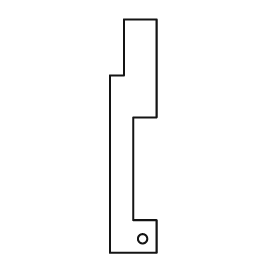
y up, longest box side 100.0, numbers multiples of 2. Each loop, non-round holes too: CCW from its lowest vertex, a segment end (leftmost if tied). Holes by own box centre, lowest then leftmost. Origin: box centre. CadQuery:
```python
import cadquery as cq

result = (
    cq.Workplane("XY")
    .moveTo(-10.0, -50.0)
    .lineTo(10.0, -50.0)
    .lineTo(10.0, -36.0)
    .lineTo(0.0, -36.0)
    .lineTo(0.0, 8.0)
    .lineTo(10.0, 8.0)
    .lineTo(10.0, 50.0)
    .lineTo(-4.0, 50.0)
    .lineTo(-4.0, 26.0)
    .lineTo(-10.0, 26.0)
    .close()
    .moveTo(4.0, -44.0)
    .circle(2.0)
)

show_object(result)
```